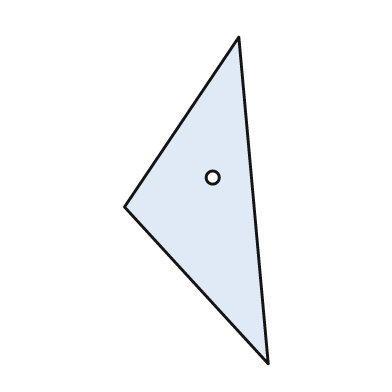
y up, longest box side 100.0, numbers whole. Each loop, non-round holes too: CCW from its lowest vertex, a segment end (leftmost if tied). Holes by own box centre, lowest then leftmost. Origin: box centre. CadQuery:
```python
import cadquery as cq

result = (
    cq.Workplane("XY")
    .moveTo(22.0, -50.0)
    .lineTo(13.0, 50.0)
    .lineTo(-22.0, -2.0)
    .close()
    .moveTo(5.0, 7.0)
    .circle(2.0)
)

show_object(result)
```